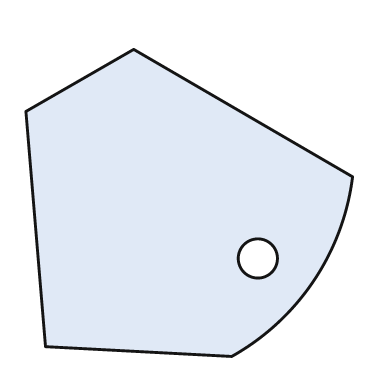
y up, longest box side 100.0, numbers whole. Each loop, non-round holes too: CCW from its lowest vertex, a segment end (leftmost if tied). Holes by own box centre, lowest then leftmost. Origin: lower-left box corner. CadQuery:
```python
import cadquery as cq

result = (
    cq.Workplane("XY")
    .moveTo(63.0, 0.0)
    .threePointArc((88.0, 23.0), (100.0, 55.0))
    .lineTo(33.0, 94.0)
    .lineTo(0.0, 75.0)
    .lineTo(6.0, 3.0)
    .close()
    .moveTo(71.0, 30.0)
    .circle(6.0)
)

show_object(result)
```